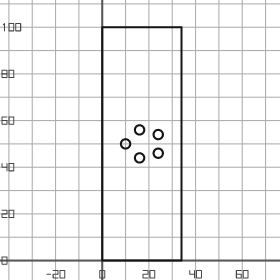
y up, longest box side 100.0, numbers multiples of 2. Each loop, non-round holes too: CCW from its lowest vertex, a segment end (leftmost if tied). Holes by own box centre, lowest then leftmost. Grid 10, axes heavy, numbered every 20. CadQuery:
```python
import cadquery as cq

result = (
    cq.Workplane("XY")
    .moveTo(0.0, 0.0)
    .lineTo(34.0, 0.0)
    .lineTo(34.0, 100.0)
    .lineTo(0.0, 100.0)
    .close()
    .moveTo(16.0, 44.0)
    .circle(2.0)
    .moveTo(24.0, 46.0)
    .circle(2.0)
    .moveTo(10.0, 50.0)
    .circle(2.0)
    .moveTo(24.0, 54.0)
    .circle(2.0)
    .moveTo(16.0, 56.0)
    .circle(2.0)
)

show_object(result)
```